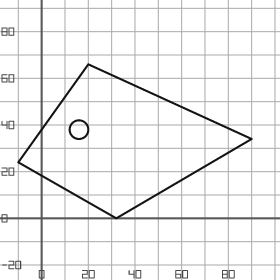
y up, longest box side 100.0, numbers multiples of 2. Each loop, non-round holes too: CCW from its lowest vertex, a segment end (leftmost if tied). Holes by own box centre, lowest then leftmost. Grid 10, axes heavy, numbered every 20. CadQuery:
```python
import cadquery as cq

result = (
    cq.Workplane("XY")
    .moveTo(32.0, 0.0)
    .lineTo(90.0, 34.0)
    .lineTo(20.0, 66.0)
    .lineTo(-10.0, 24.0)
    .close()
    .moveTo(16.0, 38.0)
    .circle(4.0)
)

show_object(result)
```